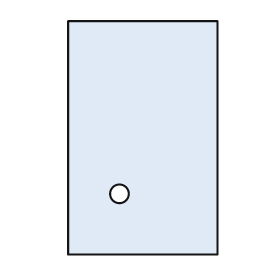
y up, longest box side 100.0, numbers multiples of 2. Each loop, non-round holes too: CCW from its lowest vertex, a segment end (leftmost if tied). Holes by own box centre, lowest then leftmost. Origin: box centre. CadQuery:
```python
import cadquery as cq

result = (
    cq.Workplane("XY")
    .moveTo(-32.0, -50.0)
    .lineTo(32.0, -50.0)
    .lineTo(32.0, 50.0)
    .lineTo(-32.0, 50.0)
    .close()
    .moveTo(-10.0, -24.0)
    .circle(4.0)
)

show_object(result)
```